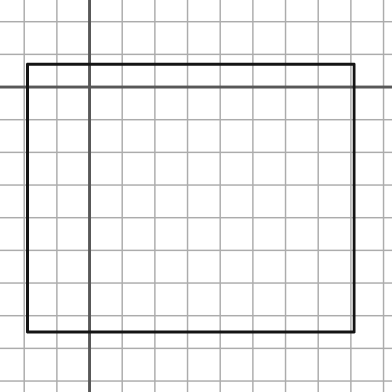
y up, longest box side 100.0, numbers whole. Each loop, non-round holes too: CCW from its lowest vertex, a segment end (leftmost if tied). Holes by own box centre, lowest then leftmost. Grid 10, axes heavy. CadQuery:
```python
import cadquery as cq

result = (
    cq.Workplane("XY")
    .moveTo(-19.0, -75.0)
    .lineTo(81.0, -75.0)
    .lineTo(81.0, 7.0)
    .lineTo(-19.0, 7.0)
    .close()
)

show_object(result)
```